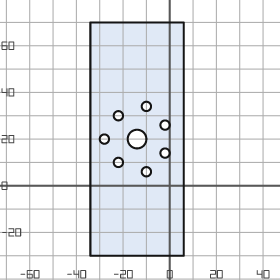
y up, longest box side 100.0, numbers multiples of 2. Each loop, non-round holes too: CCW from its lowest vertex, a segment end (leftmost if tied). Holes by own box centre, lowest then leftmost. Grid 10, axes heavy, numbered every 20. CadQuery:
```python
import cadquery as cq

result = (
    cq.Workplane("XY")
    .moveTo(-34.0, -30.0)
    .lineTo(6.0, -30.0)
    .lineTo(6.0, 70.0)
    .lineTo(-34.0, 70.0)
    .close()
    .moveTo(-10.0, 6.0)
    .circle(2.0)
    .moveTo(-22.0, 10.0)
    .circle(2.0)
    .moveTo(-2.0, 14.0)
    .circle(2.0)
    .moveTo(-28.0, 20.0)
    .circle(2.0)
    .moveTo(-14.0, 20.0)
    .circle(4.0)
    .moveTo(-2.0, 26.0)
    .circle(2.0)
    .moveTo(-22.0, 30.0)
    .circle(2.0)
    .moveTo(-10.0, 34.0)
    .circle(2.0)
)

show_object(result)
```